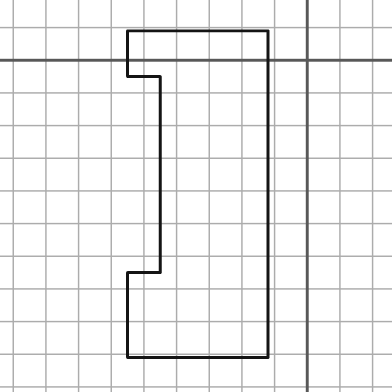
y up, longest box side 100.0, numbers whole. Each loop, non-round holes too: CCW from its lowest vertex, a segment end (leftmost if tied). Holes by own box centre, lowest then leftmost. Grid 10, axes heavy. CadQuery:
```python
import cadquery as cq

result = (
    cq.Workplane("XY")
    .moveTo(-55.0, -91.0)
    .lineTo(-12.0, -91.0)
    .lineTo(-12.0, 9.0)
    .lineTo(-55.0, 9.0)
    .lineTo(-55.0, -5.0)
    .lineTo(-45.0, -5.0)
    .lineTo(-45.0, -65.0)
    .lineTo(-55.0, -65.0)
    .close()
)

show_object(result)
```